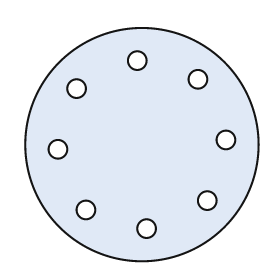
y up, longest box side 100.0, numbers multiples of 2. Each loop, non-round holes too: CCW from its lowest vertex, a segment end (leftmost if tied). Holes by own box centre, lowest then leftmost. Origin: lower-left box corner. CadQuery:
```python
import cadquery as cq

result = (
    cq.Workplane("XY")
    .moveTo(50.0, 50.0)
    .circle(50.0)
    .moveTo(52.0, 14.0)
    .circle(4.0)
    .moveTo(26.0, 22.0)
    .circle(4.0)
    .moveTo(78.0, 26.0)
    .circle(4.0)
    .moveTo(14.0, 48.0)
    .circle(4.0)
    .moveTo(86.0, 52.0)
    .circle(4.0)
    .moveTo(22.0, 74.0)
    .circle(4.0)
    .moveTo(74.0, 78.0)
    .circle(4.0)
    .moveTo(48.0, 86.0)
    .circle(4.0)
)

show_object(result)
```